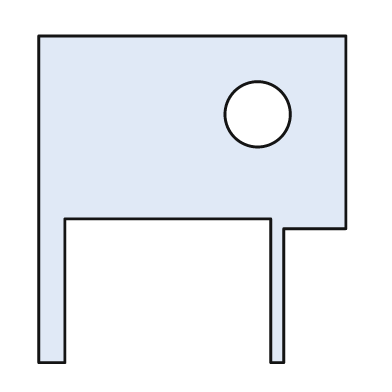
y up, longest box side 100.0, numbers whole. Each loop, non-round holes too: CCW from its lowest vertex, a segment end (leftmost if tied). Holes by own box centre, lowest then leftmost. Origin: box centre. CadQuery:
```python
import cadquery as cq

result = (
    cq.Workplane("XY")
    .moveTo(-47.0, -50.0)
    .lineTo(-39.0, -50.0)
    .lineTo(-39.0, -6.0)
    .lineTo(24.0, -6.0)
    .lineTo(24.0, -50.0)
    .lineTo(28.0, -50.0)
    .lineTo(28.0, -9.0)
    .lineTo(47.0, -9.0)
    .lineTo(47.0, 50.0)
    .lineTo(-47.0, 50.0)
    .close()
    .moveTo(20.0, 26.0)
    .circle(10.0)
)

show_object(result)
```